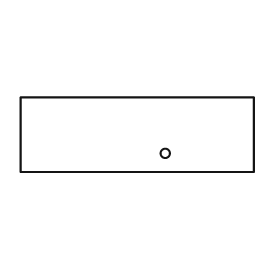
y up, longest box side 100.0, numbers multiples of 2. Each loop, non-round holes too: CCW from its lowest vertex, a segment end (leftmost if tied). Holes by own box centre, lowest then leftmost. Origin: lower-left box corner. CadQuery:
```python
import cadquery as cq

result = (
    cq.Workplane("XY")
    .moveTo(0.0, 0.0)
    .lineTo(100.0, 0.0)
    .lineTo(100.0, 32.0)
    .lineTo(0.0, 32.0)
    .close()
    .moveTo(62.0, 8.0)
    .circle(2.0)
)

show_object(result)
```